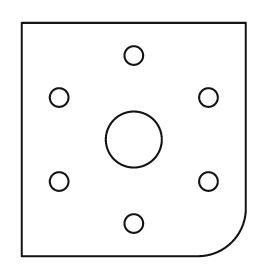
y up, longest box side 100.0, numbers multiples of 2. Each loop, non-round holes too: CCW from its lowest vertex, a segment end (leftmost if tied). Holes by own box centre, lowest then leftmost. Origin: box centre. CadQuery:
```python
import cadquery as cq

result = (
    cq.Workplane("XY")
    .moveTo(-48.0, -50.0)
    .lineTo(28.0, -50.0)
    .threePointArc((42.0, -44.0), (48.0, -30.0))
    .lineTo(48.0, 50.0)
    .lineTo(-48.0, 50.0)
    .close()
    .moveTo(0.0, -36.0)
    .circle(4.0)
    .moveTo(-32.0, -18.0)
    .circle(4.0)
    .moveTo(32.0, -18.0)
    .circle(4.0)
    .moveTo(0.0, 0.0)
    .circle(12.0)
    .moveTo(-32.0, 18.0)
    .circle(4.0)
    .moveTo(32.0, 18.0)
    .circle(4.0)
    .moveTo(0.0, 36.0)
    .circle(4.0)
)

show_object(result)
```